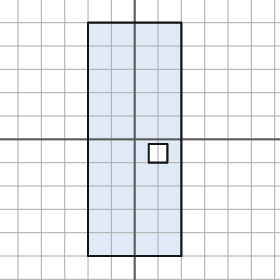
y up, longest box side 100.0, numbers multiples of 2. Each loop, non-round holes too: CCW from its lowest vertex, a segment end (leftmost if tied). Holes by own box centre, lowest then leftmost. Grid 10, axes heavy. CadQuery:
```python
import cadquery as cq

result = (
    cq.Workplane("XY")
    .moveTo(-20.0, -50.0)
    .lineTo(20.0, -50.0)
    .lineTo(20.0, 50.0)
    .lineTo(-20.0, 50.0)
    .close()
    .moveTo(6.0, -10.0)
    .lineTo(14.0, -10.0)
    .lineTo(14.0, -2.0)
    .lineTo(6.0, -2.0)
    .close()
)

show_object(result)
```